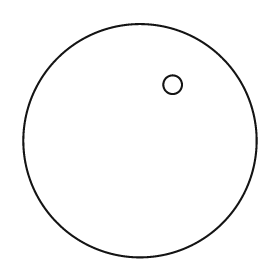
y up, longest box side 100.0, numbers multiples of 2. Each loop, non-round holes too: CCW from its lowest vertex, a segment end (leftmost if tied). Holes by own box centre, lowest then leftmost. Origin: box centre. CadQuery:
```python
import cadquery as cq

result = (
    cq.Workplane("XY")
    .moveTo(0.0, 0.0)
    .circle(50.0)
    .moveTo(14.0, 24.0)
    .circle(4.0)
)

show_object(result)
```